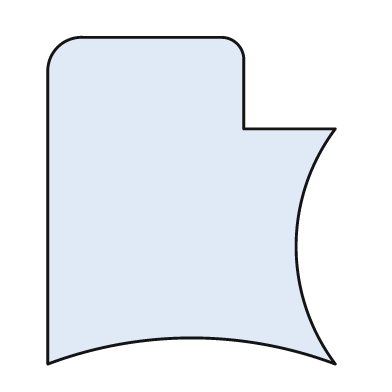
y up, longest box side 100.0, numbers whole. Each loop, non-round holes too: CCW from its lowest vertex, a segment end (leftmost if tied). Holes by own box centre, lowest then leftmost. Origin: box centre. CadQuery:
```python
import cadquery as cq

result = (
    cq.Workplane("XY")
    .moveTo(-44.0, -50.0)
    .threePointArc((0.0, -42.0), (44.0, -50.0))
    .threePointArc((32.0, -14.0), (44.0, 22.0))
    .lineTo(16.0, 22.0)
    .lineTo(16.0, 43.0)
    .threePointArc((14.0, 48.0), (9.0, 50.0))
    .lineTo(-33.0, 50.0)
    .threePointArc((-41.0, 47.0), (-44.0, 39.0))
    .close()
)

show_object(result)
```